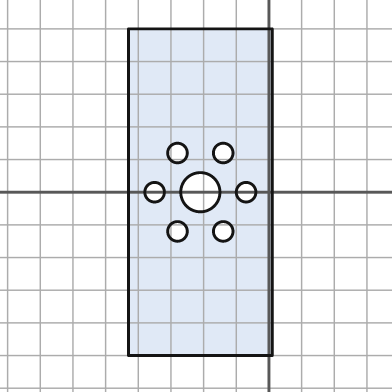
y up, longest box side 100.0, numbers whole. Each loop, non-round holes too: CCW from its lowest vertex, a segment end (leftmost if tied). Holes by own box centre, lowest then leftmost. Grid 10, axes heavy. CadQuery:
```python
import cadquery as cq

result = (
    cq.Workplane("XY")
    .moveTo(-43.0, -50.0)
    .lineTo(1.0, -50.0)
    .lineTo(1.0, 50.0)
    .lineTo(-43.0, 50.0)
    .close()
    .moveTo(-28.0, -12.0)
    .circle(3.0)
    .moveTo(-14.0, -12.0)
    .circle(3.0)
    .moveTo(-35.0, 0.0)
    .circle(3.0)
    .moveTo(-21.0, 0.0)
    .circle(6.0)
    .moveTo(-7.0, 0.0)
    .circle(3.0)
    .moveTo(-28.0, 12.0)
    .circle(3.0)
    .moveTo(-14.0, 12.0)
    .circle(3.0)
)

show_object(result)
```